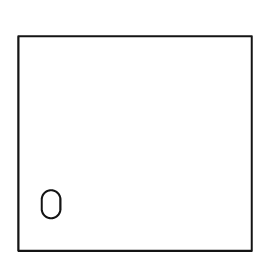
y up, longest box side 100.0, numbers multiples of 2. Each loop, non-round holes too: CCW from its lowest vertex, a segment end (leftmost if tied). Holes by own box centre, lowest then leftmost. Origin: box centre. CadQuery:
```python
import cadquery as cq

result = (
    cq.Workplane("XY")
    .moveTo(-50.0, -46.0)
    .lineTo(50.0, -46.0)
    .lineTo(50.0, 46.0)
    .lineTo(-50.0, 46.0)
    .close()
    .moveTo(-40.0, -28.0)
    .threePointArc((-36.0, -32.0), (-32.0, -28.0))
    .lineTo(-32.0, -24.0)
    .threePointArc((-36.0, -20.0), (-40.0, -24.0))
    .close()
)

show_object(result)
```